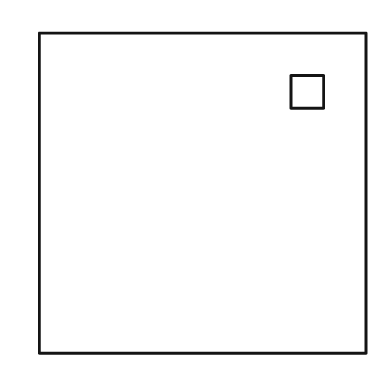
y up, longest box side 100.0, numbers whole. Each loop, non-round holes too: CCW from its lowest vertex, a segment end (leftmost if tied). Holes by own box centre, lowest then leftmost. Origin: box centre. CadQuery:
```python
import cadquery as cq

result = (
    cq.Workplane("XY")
    .moveTo(-50.0, -49.0)
    .lineTo(50.0, -49.0)
    .lineTo(50.0, 49.0)
    .lineTo(-50.0, 49.0)
    .close()
    .moveTo(27.0, 26.0)
    .lineTo(37.0, 26.0)
    .lineTo(37.0, 36.0)
    .lineTo(27.0, 36.0)
    .close()
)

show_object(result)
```